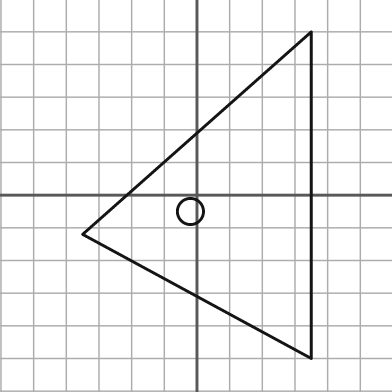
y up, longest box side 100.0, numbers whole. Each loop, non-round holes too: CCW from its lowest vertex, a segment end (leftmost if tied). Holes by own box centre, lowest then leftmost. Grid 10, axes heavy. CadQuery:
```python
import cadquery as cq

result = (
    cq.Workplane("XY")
    .moveTo(35.0, -50.0)
    .lineTo(35.0, 50.0)
    .lineTo(-35.0, -12.0)
    .close()
    .moveTo(-2.0, -5.0)
    .circle(4.0)
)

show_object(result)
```